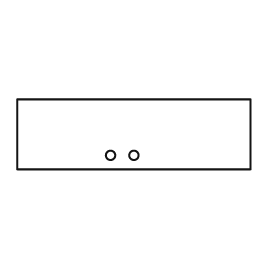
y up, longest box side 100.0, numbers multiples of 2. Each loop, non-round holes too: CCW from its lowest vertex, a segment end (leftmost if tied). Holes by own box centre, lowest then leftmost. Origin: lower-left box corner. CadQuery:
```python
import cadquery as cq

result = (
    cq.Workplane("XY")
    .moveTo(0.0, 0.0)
    .lineTo(100.0, 0.0)
    .lineTo(100.0, 30.0)
    .lineTo(0.0, 30.0)
    .close()
    .moveTo(40.0, 6.0)
    .circle(2.0)
    .moveTo(50.0, 6.0)
    .circle(2.0)
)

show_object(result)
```